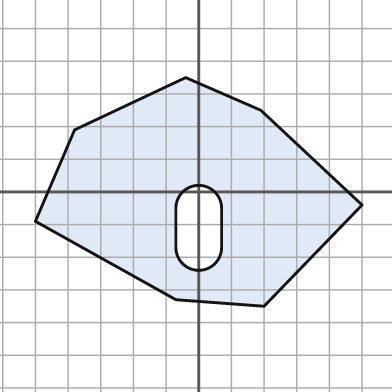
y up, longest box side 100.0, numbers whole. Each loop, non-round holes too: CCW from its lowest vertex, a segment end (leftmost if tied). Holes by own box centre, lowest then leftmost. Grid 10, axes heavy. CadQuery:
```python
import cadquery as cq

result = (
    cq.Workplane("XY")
    .moveTo(20.0, -35.0)
    .lineTo(50.0, -4.0)
    .lineTo(19.0, 25.0)
    .lineTo(-4.0, 35.0)
    .lineTo(-38.0, 19.0)
    .lineTo(-50.0, -9.0)
    .lineTo(-7.0, -33.0)
    .close()
    .moveTo(-7.0, -17.0)
    .threePointArc((0.0, -24.0), (7.0, -17.0))
    .lineTo(7.0, -5.0)
    .threePointArc((0.0, 2.0), (-7.0, -5.0))
    .close()
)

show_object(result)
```